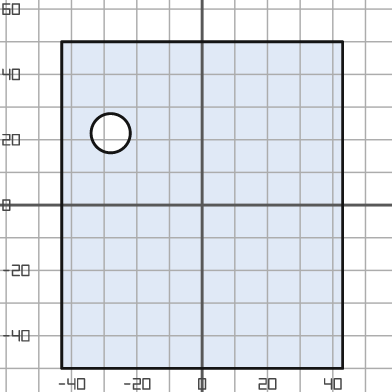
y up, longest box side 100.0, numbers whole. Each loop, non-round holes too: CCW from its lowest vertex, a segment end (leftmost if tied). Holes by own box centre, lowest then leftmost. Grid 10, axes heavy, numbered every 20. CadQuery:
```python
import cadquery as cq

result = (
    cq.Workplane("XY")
    .moveTo(-43.0, -50.0)
    .lineTo(43.0, -50.0)
    .lineTo(43.0, 50.0)
    .lineTo(-43.0, 50.0)
    .close()
    .moveTo(-28.0, 22.0)
    .circle(6.0)
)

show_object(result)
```